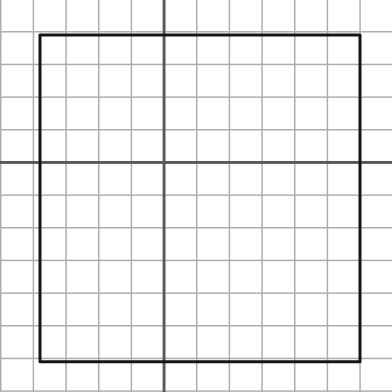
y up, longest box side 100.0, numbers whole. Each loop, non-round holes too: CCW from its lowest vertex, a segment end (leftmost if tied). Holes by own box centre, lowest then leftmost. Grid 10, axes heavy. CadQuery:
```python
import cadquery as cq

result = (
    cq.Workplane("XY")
    .moveTo(-38.0, -61.0)
    .lineTo(60.0, -61.0)
    .lineTo(60.0, 39.0)
    .lineTo(-38.0, 39.0)
    .close()
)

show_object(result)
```